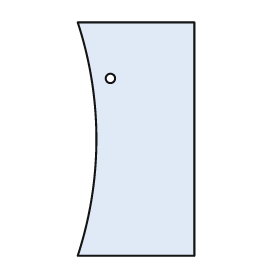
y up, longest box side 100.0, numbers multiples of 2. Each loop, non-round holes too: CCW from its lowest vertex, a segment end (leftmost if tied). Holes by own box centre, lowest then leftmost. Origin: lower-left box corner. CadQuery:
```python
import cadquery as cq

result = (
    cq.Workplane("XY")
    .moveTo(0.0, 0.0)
    .lineTo(50.0, 0.0)
    .lineTo(50.0, 100.0)
    .lineTo(0.0, 100.0)
    .threePointArc((8.0, 50.0), (0.0, 0.0))
    .close()
    .moveTo(14.0, 76.0)
    .circle(2.0)
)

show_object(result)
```